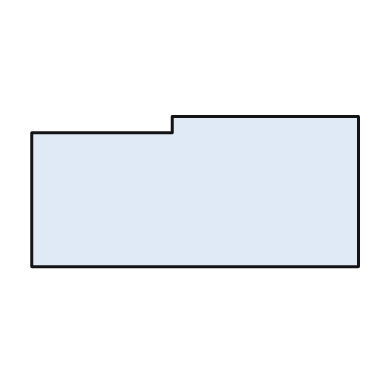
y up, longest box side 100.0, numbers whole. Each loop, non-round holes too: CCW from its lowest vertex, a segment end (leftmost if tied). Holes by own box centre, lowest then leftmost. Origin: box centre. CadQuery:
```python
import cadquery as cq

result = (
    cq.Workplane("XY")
    .moveTo(-50.0, -23.0)
    .lineTo(50.0, -23.0)
    .lineTo(50.0, 23.0)
    .lineTo(-7.0, 23.0)
    .lineTo(-7.0, 18.0)
    .lineTo(-50.0, 18.0)
    .close()
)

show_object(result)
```